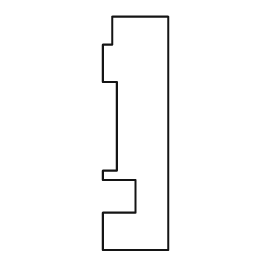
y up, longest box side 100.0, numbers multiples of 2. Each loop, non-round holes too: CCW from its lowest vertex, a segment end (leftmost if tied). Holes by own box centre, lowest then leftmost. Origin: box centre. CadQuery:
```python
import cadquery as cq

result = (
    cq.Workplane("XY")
    .moveTo(-14.0, -50.0)
    .lineTo(14.0, -50.0)
    .lineTo(14.0, 50.0)
    .lineTo(-10.0, 50.0)
    .lineTo(-10.0, 38.0)
    .lineTo(-14.0, 38.0)
    .lineTo(-14.0, 22.0)
    .lineTo(-8.0, 22.0)
    .lineTo(-8.0, -16.0)
    .lineTo(-14.0, -16.0)
    .lineTo(-14.0, -20.0)
    .lineTo(0.0, -20.0)
    .lineTo(0.0, -34.0)
    .lineTo(-14.0, -34.0)
    .close()
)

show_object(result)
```